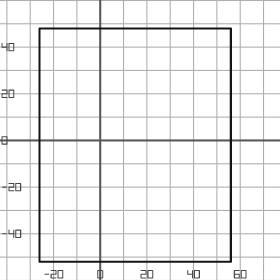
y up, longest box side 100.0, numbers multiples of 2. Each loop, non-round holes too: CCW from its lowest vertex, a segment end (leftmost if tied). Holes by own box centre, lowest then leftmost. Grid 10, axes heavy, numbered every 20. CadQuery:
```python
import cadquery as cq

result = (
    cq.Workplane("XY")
    .moveTo(-26.0, -52.0)
    .lineTo(56.0, -52.0)
    .lineTo(56.0, 48.0)
    .lineTo(-26.0, 48.0)
    .close()
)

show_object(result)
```